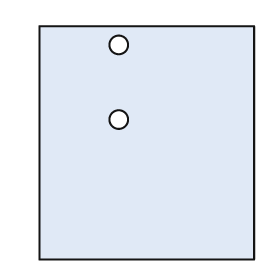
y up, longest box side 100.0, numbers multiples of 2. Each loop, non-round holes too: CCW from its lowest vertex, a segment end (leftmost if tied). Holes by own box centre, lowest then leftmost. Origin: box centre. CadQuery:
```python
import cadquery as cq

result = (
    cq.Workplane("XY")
    .moveTo(-46.0, -50.0)
    .lineTo(46.0, -50.0)
    .lineTo(46.0, 50.0)
    .lineTo(-46.0, 50.0)
    .close()
    .moveTo(-12.0, 10.0)
    .circle(4.0)
    .moveTo(-12.0, 42.0)
    .circle(4.0)
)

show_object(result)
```